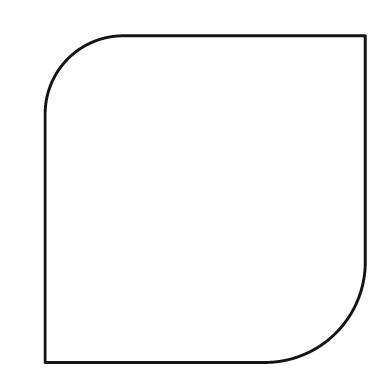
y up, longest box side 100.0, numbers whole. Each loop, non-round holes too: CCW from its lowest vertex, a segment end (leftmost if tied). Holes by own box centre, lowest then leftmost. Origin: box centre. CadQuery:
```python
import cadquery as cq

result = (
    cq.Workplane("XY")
    .moveTo(-49.0, -50.0)
    .lineTo(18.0, -50.0)
    .threePointArc((40.0, -41.0), (49.0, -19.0))
    .lineTo(49.0, 50.0)
    .lineTo(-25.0, 50.0)
    .threePointArc((-42.0, 43.0), (-49.0, 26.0))
    .close()
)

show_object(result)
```